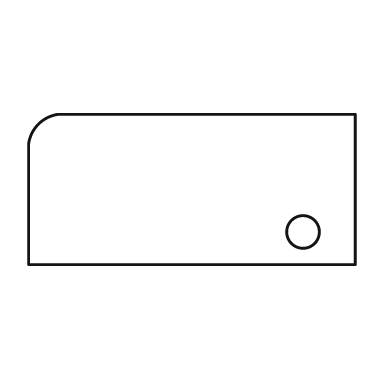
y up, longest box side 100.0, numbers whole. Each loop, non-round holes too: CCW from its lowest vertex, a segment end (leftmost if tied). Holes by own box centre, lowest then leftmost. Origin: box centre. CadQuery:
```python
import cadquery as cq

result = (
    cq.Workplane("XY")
    .moveTo(-50.0, -23.0)
    .lineTo(50.0, -23.0)
    .lineTo(50.0, 23.0)
    .lineTo(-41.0, 23.0)
    .threePointArc((-47.0, 20.0), (-50.0, 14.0))
    .close()
    .moveTo(34.0, -13.0)
    .circle(5.0)
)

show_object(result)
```